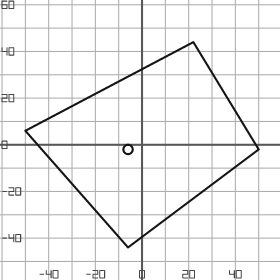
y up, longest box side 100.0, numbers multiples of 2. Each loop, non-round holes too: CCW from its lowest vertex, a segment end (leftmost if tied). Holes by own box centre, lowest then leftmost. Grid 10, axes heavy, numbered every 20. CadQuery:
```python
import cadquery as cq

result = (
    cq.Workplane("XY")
    .moveTo(-6.0, -44.0)
    .lineTo(50.0, -2.0)
    .lineTo(22.0, 44.0)
    .lineTo(-50.0, 6.0)
    .close()
    .moveTo(-6.0, -2.0)
    .circle(2.0)
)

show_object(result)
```